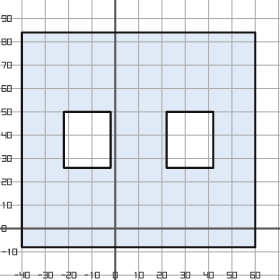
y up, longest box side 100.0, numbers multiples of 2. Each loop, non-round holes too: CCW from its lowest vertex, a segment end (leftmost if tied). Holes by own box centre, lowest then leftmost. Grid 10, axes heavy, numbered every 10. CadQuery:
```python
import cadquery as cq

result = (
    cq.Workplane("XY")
    .moveTo(-40.0, -8.0)
    .lineTo(60.0, -8.0)
    .lineTo(60.0, 84.0)
    .lineTo(-40.0, 84.0)
    .close()
    .moveTo(-22.0, 26.0)
    .lineTo(-2.0, 26.0)
    .lineTo(-2.0, 50.0)
    .lineTo(-22.0, 50.0)
    .close()
    .moveTo(22.0, 26.0)
    .lineTo(42.0, 26.0)
    .lineTo(42.0, 50.0)
    .lineTo(22.0, 50.0)
    .close()
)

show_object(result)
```